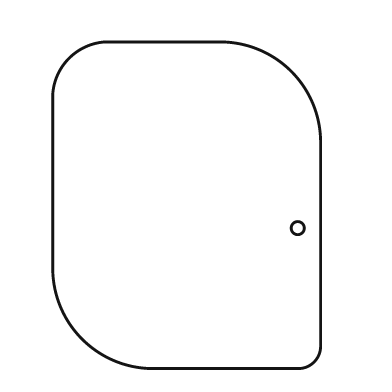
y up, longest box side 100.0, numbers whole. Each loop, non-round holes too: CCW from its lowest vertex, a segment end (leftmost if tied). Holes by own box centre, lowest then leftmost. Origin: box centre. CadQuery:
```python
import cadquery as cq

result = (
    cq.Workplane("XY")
    .moveTo(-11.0, -50.0)
    .lineTo(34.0, -50.0)
    .threePointArc((39.0, -48.0), (41.0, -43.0))
    .lineTo(41.0, 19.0)
    .threePointArc((32.0, 41.0), (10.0, 50.0))
    .lineTo(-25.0, 50.0)
    .threePointArc((-36.0, 45.0), (-41.0, 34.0))
    .lineTo(-41.0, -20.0)
    .threePointArc((-32.0, -41.0), (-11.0, -50.0))
    .close()
    .moveTo(34.0, -7.0)
    .circle(2.0)
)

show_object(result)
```